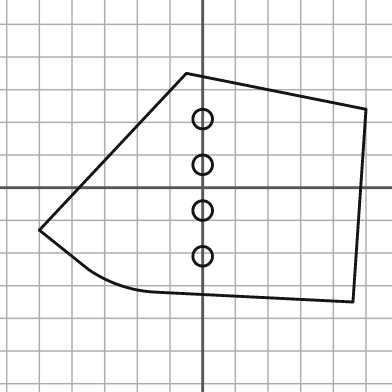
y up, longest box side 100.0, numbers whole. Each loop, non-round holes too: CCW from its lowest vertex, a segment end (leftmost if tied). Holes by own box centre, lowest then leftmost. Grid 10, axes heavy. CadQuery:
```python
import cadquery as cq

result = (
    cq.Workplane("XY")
    .moveTo(46.0, -35.0)
    .lineTo(50.0, 24.0)
    .lineTo(-5.0, 35.0)
    .lineTo(-50.0, -13.0)
    .lineTo(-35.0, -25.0)
    .threePointArc((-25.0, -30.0), (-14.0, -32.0))
    .close()
    .moveTo(0.0, -21.0)
    .circle(3.0)
    .moveTo(0.0, -7.0)
    .circle(3.0)
    .moveTo(0.0, 7.0)
    .circle(3.0)
    .moveTo(0.0, 21.0)
    .circle(3.0)
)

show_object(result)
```